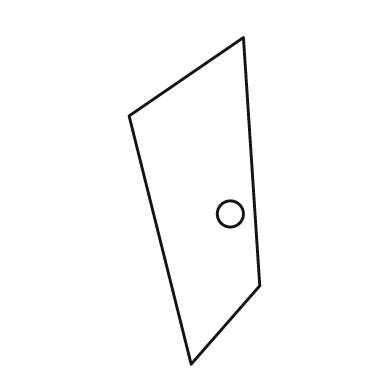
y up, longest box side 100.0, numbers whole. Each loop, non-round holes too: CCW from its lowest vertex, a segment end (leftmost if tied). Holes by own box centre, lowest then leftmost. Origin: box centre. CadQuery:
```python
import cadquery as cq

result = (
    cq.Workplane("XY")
    .moveTo(-1.0, -50.0)
    .lineTo(20.0, -26.0)
    .lineTo(15.0, 50.0)
    .lineTo(-20.0, 26.0)
    .close()
    .moveTo(11.0, -4.0)
    .circle(4.0)
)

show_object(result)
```